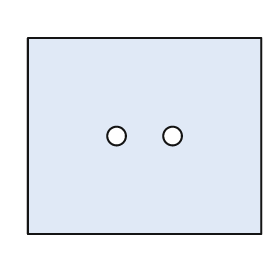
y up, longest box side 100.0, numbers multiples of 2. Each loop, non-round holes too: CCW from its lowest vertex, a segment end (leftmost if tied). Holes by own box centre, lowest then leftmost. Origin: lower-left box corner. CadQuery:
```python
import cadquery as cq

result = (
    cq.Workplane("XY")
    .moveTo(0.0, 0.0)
    .lineTo(100.0, 0.0)
    .lineTo(100.0, 84.0)
    .lineTo(0.0, 84.0)
    .close()
    .moveTo(38.0, 42.0)
    .circle(4.0)
    .moveTo(62.0, 42.0)
    .circle(4.0)
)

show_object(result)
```